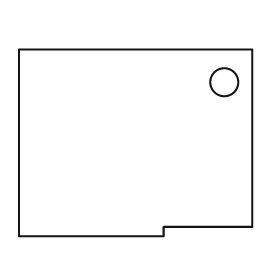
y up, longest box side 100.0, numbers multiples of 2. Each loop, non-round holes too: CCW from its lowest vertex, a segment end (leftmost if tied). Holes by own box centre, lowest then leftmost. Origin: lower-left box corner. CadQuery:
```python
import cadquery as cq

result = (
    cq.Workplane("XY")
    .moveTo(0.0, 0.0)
    .lineTo(62.0, 0.0)
    .lineTo(62.0, 4.0)
    .lineTo(100.0, 4.0)
    .lineTo(100.0, 80.0)
    .lineTo(0.0, 80.0)
    .close()
    .moveTo(88.0, 66.0)
    .circle(6.0)
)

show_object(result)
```